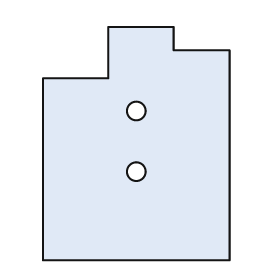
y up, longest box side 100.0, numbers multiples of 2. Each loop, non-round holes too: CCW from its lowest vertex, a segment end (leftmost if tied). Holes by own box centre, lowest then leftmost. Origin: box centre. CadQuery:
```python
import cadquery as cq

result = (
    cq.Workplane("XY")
    .moveTo(-40.0, -50.0)
    .lineTo(40.0, -50.0)
    .lineTo(40.0, 40.0)
    .lineTo(16.0, 40.0)
    .lineTo(16.0, 50.0)
    .lineTo(-12.0, 50.0)
    .lineTo(-12.0, 28.0)
    .lineTo(-40.0, 28.0)
    .close()
    .moveTo(0.0, -12.0)
    .circle(4.0)
    .moveTo(0.0, 14.0)
    .circle(4.0)
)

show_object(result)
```